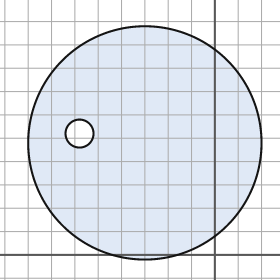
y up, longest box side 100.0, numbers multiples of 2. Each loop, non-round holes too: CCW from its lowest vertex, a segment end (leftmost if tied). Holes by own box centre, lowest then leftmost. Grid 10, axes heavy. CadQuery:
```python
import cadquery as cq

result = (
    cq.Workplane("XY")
    .moveTo(-30.0, 48.0)
    .circle(50.0)
    .moveTo(-58.0, 52.0)
    .circle(6.0)
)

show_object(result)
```